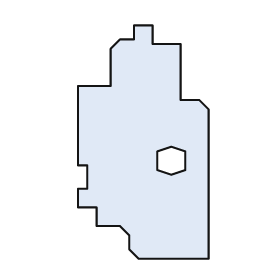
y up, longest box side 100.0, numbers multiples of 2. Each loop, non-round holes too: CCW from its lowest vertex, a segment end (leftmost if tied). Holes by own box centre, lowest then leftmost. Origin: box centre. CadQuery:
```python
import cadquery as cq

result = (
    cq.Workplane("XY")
    .moveTo(-2.0, -50.0)
    .lineTo(28.0, -50.0)
    .lineTo(28.0, 14.0)
    .lineTo(24.0, 18.0)
    .lineTo(16.0, 18.0)
    .lineTo(16.0, 42.0)
    .lineTo(4.0, 42.0)
    .lineTo(4.0, 50.0)
    .lineTo(-4.0, 50.0)
    .lineTo(-4.0, 44.0)
    .lineTo(-10.0, 44.0)
    .lineTo(-14.0, 40.0)
    .lineTo(-14.0, 24.0)
    .lineTo(-28.0, 24.0)
    .lineTo(-28.0, -10.0)
    .lineTo(-24.0, -10.0)
    .lineTo(-24.0, -20.0)
    .lineTo(-28.0, -20.0)
    .lineTo(-28.0, -28.0)
    .lineTo(-20.0, -28.0)
    .lineTo(-20.0, -36.0)
    .lineTo(-10.0, -36.0)
    .lineTo(-6.0, -40.0)
    .lineTo(-6.0, -46.0)
    .close()
    .moveTo(12.0, -14.0)
    .lineTo(18.0, -12.0)
    .lineTo(18.0, -4.0)
    .lineTo(12.0, -2.0)
    .lineTo(6.0, -4.0)
    .lineTo(6.0, -12.0)
    .close()
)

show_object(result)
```